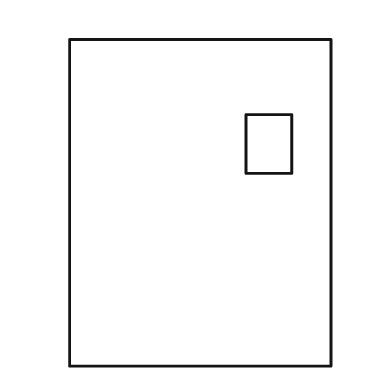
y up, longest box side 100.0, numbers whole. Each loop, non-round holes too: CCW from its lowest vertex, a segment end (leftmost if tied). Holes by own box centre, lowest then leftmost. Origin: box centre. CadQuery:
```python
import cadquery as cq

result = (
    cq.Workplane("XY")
    .moveTo(-40.0, -50.0)
    .lineTo(40.0, -50.0)
    .lineTo(40.0, 50.0)
    .lineTo(-40.0, 50.0)
    .close()
    .moveTo(14.0, 9.0)
    .lineTo(28.0, 9.0)
    .lineTo(28.0, 27.0)
    .lineTo(14.0, 27.0)
    .close()
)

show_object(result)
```